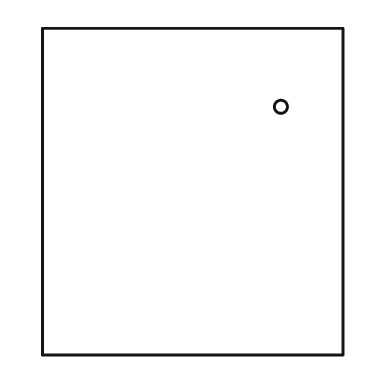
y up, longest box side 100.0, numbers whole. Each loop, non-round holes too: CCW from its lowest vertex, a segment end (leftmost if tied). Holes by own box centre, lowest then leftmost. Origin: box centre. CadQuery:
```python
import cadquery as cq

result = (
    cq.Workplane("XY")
    .moveTo(-46.0, -50.0)
    .lineTo(46.0, -50.0)
    .lineTo(46.0, 50.0)
    .lineTo(-46.0, 50.0)
    .close()
    .moveTo(27.0, 26.0)
    .circle(2.0)
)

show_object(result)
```